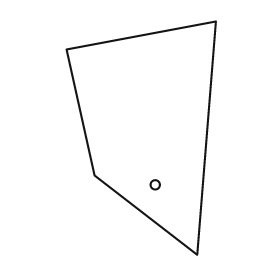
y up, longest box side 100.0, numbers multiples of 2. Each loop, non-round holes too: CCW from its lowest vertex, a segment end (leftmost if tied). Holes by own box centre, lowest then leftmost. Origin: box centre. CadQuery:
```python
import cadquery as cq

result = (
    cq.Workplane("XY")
    .moveTo(24.0, -50.0)
    .lineTo(32.0, 50.0)
    .lineTo(-32.0, 38.0)
    .lineTo(-20.0, -16.0)
    .close()
    .moveTo(6.0, -20.0)
    .circle(2.0)
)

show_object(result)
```